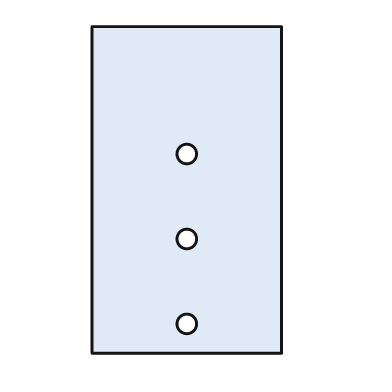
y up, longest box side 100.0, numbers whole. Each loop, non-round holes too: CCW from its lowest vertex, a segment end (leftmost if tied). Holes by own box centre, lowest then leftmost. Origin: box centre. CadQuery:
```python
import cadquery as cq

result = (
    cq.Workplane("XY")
    .moveTo(-29.0, -50.0)
    .lineTo(29.0, -50.0)
    .lineTo(29.0, 50.0)
    .lineTo(-29.0, 50.0)
    .close()
    .moveTo(0.0, -41.0)
    .circle(3.0)
    .moveTo(0.0, -15.0)
    .circle(3.0)
    .moveTo(0.0, 11.0)
    .circle(3.0)
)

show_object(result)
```